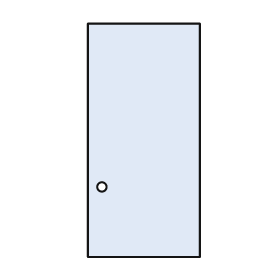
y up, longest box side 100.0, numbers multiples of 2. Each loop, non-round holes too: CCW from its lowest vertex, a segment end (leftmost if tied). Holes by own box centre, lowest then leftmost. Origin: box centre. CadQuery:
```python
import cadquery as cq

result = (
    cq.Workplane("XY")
    .moveTo(-24.0, -50.0)
    .lineTo(24.0, -50.0)
    .lineTo(24.0, 50.0)
    .lineTo(-24.0, 50.0)
    .close()
    .moveTo(-18.0, -20.0)
    .circle(2.0)
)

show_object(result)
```